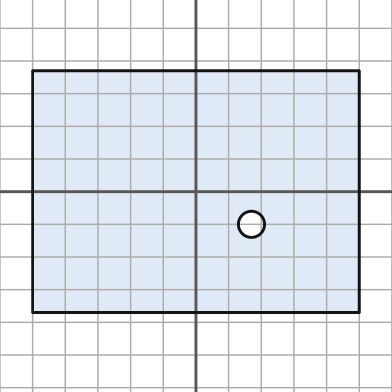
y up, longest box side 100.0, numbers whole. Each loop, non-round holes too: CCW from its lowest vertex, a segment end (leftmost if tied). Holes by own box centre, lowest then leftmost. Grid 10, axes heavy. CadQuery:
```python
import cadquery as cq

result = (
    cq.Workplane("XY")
    .moveTo(-50.0, -37.0)
    .lineTo(50.0, -37.0)
    .lineTo(50.0, 37.0)
    .lineTo(-50.0, 37.0)
    .close()
    .moveTo(17.0, -10.0)
    .circle(4.0)
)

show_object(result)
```